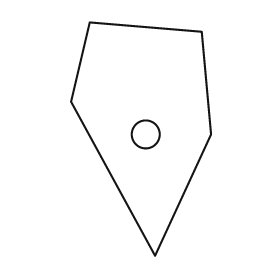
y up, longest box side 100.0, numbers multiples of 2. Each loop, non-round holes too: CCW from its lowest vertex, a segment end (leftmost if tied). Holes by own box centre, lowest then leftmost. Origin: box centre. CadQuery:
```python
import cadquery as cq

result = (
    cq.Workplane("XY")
    .moveTo(6.0, -50.0)
    .lineTo(30.0, 2.0)
    .lineTo(26.0, 46.0)
    .lineTo(-22.0, 50.0)
    .lineTo(-30.0, 16.0)
    .close()
    .moveTo(2.0, 2.0)
    .circle(6.0)
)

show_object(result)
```